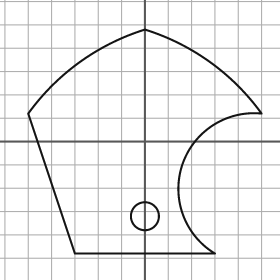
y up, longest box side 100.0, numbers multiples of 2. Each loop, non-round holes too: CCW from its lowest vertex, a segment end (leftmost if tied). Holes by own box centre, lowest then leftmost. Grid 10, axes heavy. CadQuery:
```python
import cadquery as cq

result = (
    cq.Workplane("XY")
    .moveTo(-30.0, -48.0)
    .lineTo(30.0, -48.0)
    .threePointArc((16.0, -10.0), (50.0, 12.0))
    .threePointArc((28.0, 34.0), (0.0, 48.0))
    .threePointArc((-28.0, 34.0), (-50.0, 12.0))
    .close()
    .moveTo(0.0, -32.0)
    .circle(6.0)
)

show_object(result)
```